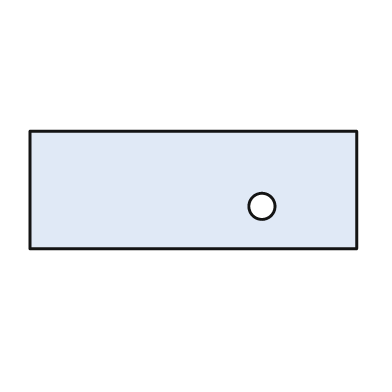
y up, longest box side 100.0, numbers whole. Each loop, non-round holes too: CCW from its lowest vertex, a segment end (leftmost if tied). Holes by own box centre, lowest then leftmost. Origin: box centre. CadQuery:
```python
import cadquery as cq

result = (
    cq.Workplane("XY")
    .moveTo(-50.0, -18.0)
    .lineTo(50.0, -18.0)
    .lineTo(50.0, 18.0)
    .lineTo(-50.0, 18.0)
    .close()
    .moveTo(21.0, -5.0)
    .circle(4.0)
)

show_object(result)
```